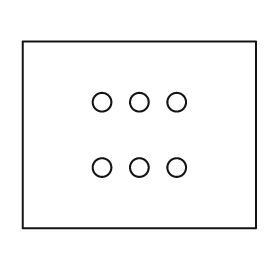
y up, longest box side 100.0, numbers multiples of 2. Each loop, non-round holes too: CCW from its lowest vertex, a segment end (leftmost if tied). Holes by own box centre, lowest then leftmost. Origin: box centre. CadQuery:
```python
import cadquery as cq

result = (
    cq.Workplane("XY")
    .moveTo(-50.0, -40.0)
    .lineTo(50.0, -40.0)
    .lineTo(50.0, 40.0)
    .lineTo(-50.0, 40.0)
    .close()
    .moveTo(-16.0, -14.0)
    .circle(4.0)
    .moveTo(0.0, -14.0)
    .circle(4.0)
    .moveTo(16.0, -14.0)
    .circle(4.0)
    .moveTo(-16.0, 14.0)
    .circle(4.0)
    .moveTo(0.0, 14.0)
    .circle(4.0)
    .moveTo(16.0, 14.0)
    .circle(4.0)
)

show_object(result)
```